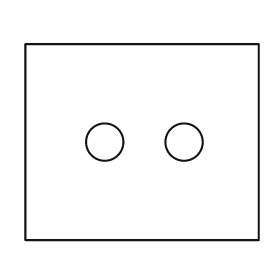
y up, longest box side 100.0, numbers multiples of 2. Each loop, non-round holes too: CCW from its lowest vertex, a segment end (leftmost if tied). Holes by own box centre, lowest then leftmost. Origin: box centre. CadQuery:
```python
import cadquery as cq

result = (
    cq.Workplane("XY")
    .moveTo(-50.0, -42.0)
    .lineTo(50.0, -42.0)
    .lineTo(50.0, 42.0)
    .lineTo(-50.0, 42.0)
    .close()
    .moveTo(-16.0, 0.0)
    .circle(8.0)
    .moveTo(18.0, 0.0)
    .circle(8.0)
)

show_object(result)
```